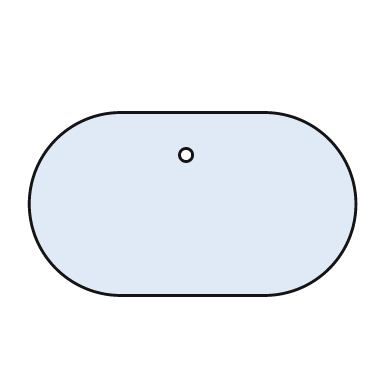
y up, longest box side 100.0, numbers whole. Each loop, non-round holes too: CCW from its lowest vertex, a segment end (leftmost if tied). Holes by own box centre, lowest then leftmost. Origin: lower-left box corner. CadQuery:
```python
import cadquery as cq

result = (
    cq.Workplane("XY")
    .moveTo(28.0, 0.0)
    .lineTo(72.0, 0.0)
    .threePointArc((100.0, 28.0), (72.0, 56.0))
    .lineTo(28.0, 56.0)
    .threePointArc((0.0, 28.0), (28.0, 0.0))
    .close()
    .moveTo(48.0, 43.0)
    .circle(2.0)
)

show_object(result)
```